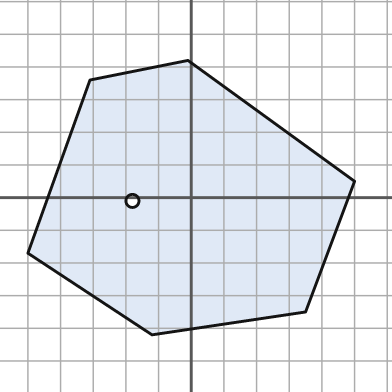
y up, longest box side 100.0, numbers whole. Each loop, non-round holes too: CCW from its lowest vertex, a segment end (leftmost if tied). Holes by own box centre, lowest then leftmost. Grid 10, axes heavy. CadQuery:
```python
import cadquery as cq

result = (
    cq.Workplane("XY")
    .moveTo(-12.0, -42.0)
    .lineTo(35.0, -35.0)
    .lineTo(50.0, 5.0)
    .lineTo(-1.0, 42.0)
    .lineTo(-31.0, 36.0)
    .lineTo(-50.0, -17.0)
    .close()
    .moveTo(-18.0, -1.0)
    .circle(2.0)
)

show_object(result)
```